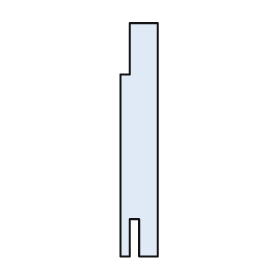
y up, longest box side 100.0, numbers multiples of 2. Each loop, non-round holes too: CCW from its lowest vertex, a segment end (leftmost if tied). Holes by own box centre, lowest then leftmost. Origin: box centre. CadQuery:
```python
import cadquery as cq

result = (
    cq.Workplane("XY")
    .moveTo(-8.0, -50.0)
    .lineTo(-4.0, -50.0)
    .lineTo(-4.0, -34.0)
    .lineTo(0.0, -34.0)
    .lineTo(0.0, -50.0)
    .lineTo(8.0, -50.0)
    .lineTo(8.0, 50.0)
    .lineTo(-4.0, 50.0)
    .lineTo(-4.0, 28.0)
    .lineTo(-8.0, 28.0)
    .close()
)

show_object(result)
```